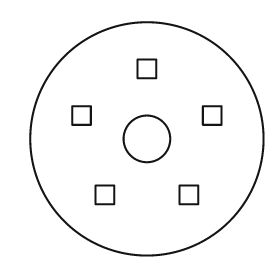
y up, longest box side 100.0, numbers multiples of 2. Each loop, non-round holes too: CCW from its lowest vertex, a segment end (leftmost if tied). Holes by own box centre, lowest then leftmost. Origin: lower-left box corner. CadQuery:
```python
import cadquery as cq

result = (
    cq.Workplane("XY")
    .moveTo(50.0, 50.0)
    .circle(50.0)
    .moveTo(28.0, 22.0)
    .lineTo(36.0, 22.0)
    .lineTo(36.0, 30.0)
    .lineTo(28.0, 30.0)
    .close()
    .moveTo(64.0, 22.0)
    .lineTo(72.0, 22.0)
    .lineTo(72.0, 30.0)
    .lineTo(64.0, 30.0)
    .close()
    .moveTo(50.0, 50.0)
    .circle(10.0)
    .moveTo(18.0, 56.0)
    .lineTo(26.0, 56.0)
    .lineTo(26.0, 64.0)
    .lineTo(18.0, 64.0)
    .close()
    .moveTo(74.0, 56.0)
    .lineTo(82.0, 56.0)
    .lineTo(82.0, 64.0)
    .lineTo(74.0, 64.0)
    .close()
    .moveTo(46.0, 76.0)
    .lineTo(54.0, 76.0)
    .lineTo(54.0, 84.0)
    .lineTo(46.0, 84.0)
    .close()
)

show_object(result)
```